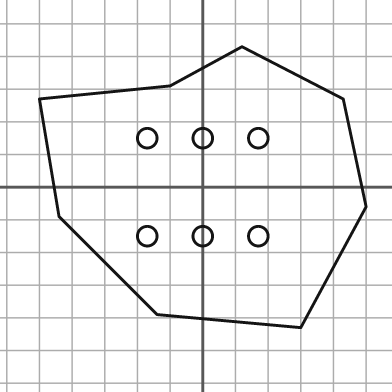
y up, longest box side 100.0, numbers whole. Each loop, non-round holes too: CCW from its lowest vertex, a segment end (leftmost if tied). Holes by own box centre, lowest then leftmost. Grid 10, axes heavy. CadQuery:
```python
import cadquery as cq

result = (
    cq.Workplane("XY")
    .moveTo(30.0, -43.0)
    .lineTo(50.0, -6.0)
    .lineTo(43.0, 27.0)
    .lineTo(12.0, 43.0)
    .lineTo(-10.0, 31.0)
    .lineTo(-50.0, 27.0)
    .lineTo(-44.0, -9.0)
    .lineTo(-14.0, -39.0)
    .close()
    .moveTo(-17.0, -15.0)
    .circle(3.0)
    .moveTo(0.0, -15.0)
    .circle(3.0)
    .moveTo(17.0, -15.0)
    .circle(3.0)
    .moveTo(-17.0, 15.0)
    .circle(3.0)
    .moveTo(0.0, 15.0)
    .circle(3.0)
    .moveTo(17.0, 15.0)
    .circle(3.0)
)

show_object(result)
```